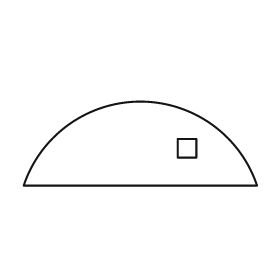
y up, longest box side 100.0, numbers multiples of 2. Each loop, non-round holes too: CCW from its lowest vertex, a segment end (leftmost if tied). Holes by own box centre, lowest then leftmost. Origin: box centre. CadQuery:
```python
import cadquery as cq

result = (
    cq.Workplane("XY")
    .moveTo(-50.0, -18.0)
    .lineTo(50.0, -18.0)
    .threePointArc((0.0, 18.0), (-50.0, -18.0))
    .close()
    .moveTo(16.0, -6.0)
    .lineTo(24.0, -6.0)
    .lineTo(24.0, 2.0)
    .lineTo(16.0, 2.0)
    .close()
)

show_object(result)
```